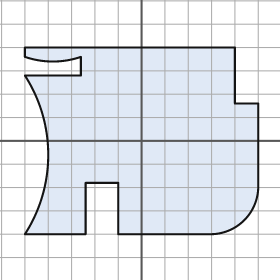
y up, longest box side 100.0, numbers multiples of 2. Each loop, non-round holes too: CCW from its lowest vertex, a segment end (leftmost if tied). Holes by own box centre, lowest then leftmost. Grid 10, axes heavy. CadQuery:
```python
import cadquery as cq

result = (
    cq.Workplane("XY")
    .moveTo(-50.0, -40.0)
    .lineTo(-24.0, -40.0)
    .lineTo(-24.0, -18.0)
    .lineTo(-10.0, -18.0)
    .lineTo(-10.0, -40.0)
    .lineTo(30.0, -40.0)
    .threePointArc((44.0, -34.0), (50.0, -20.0))
    .lineTo(50.0, 16.0)
    .lineTo(40.0, 16.0)
    .lineTo(40.0, 40.0)
    .lineTo(-50.0, 40.0)
    .lineTo(-50.0, 36.0)
    .threePointArc((-38.0, 34.0), (-26.0, 36.0))
    .lineTo(-26.0, 28.0)
    .lineTo(-50.0, 28.0)
    .threePointArc((-40.0, -6.0), (-50.0, -40.0))
    .close()
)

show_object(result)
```